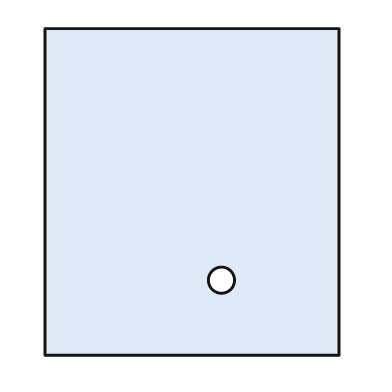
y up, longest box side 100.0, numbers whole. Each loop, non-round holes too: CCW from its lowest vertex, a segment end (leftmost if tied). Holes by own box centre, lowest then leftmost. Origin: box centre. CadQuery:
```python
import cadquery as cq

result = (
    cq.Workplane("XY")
    .moveTo(-45.0, -50.0)
    .lineTo(45.0, -50.0)
    .lineTo(45.0, 50.0)
    .lineTo(-45.0, 50.0)
    .close()
    .moveTo(9.0, -27.0)
    .circle(4.0)
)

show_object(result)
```